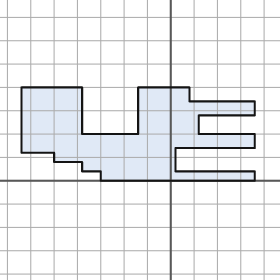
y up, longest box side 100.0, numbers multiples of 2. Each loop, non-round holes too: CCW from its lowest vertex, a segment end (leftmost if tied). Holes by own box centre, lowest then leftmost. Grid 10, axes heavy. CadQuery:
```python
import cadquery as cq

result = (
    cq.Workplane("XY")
    .moveTo(-30.0, 0.0)
    .lineTo(36.0, 0.0)
    .lineTo(36.0, 4.0)
    .lineTo(2.0, 4.0)
    .lineTo(2.0, 14.0)
    .lineTo(36.0, 14.0)
    .lineTo(36.0, 20.0)
    .lineTo(12.0, 20.0)
    .lineTo(12.0, 28.0)
    .lineTo(36.0, 28.0)
    .lineTo(36.0, 34.0)
    .lineTo(8.0, 34.0)
    .lineTo(8.0, 40.0)
    .lineTo(-14.0, 40.0)
    .lineTo(-14.0, 20.0)
    .lineTo(-38.0, 20.0)
    .lineTo(-38.0, 40.0)
    .lineTo(-64.0, 40.0)
    .lineTo(-64.0, 12.0)
    .lineTo(-50.0, 12.0)
    .lineTo(-50.0, 8.0)
    .lineTo(-38.0, 8.0)
    .lineTo(-38.0, 4.0)
    .lineTo(-30.0, 4.0)
    .close()
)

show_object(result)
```